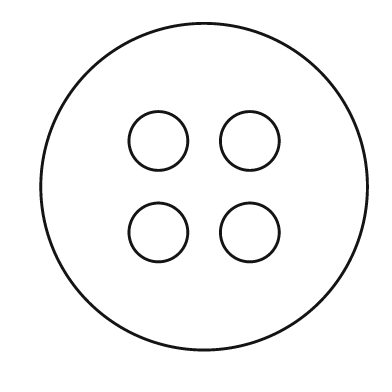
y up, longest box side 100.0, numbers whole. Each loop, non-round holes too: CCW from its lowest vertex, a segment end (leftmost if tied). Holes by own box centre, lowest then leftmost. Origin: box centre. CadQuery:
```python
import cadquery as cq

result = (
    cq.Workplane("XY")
    .moveTo(0.0, 0.0)
    .circle(50.0)
    .moveTo(-14.0, -14.0)
    .circle(9.0)
    .moveTo(14.0, -14.0)
    .circle(9.0)
    .moveTo(-14.0, 14.0)
    .circle(9.0)
    .moveTo(14.0, 14.0)
    .circle(9.0)
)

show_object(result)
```